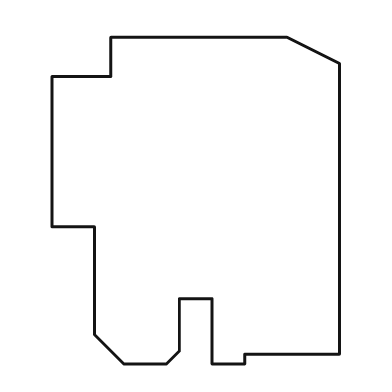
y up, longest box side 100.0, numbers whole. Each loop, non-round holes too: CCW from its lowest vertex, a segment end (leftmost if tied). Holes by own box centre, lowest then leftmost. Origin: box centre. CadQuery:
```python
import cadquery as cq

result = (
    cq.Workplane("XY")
    .moveTo(-22.0, -50.0)
    .lineTo(-9.0, -50.0)
    .lineTo(-5.0, -46.0)
    .lineTo(-5.0, -30.0)
    .lineTo(5.0, -30.0)
    .lineTo(5.0, -50.0)
    .lineTo(15.0, -50.0)
    .lineTo(15.0, -47.0)
    .lineTo(44.0, -47.0)
    .lineTo(44.0, 42.0)
    .lineTo(28.0, 50.0)
    .lineTo(-26.0, 50.0)
    .lineTo(-26.0, 38.0)
    .lineTo(-44.0, 38.0)
    .lineTo(-44.0, -8.0)
    .lineTo(-31.0, -8.0)
    .lineTo(-31.0, -41.0)
    .close()
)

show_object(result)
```